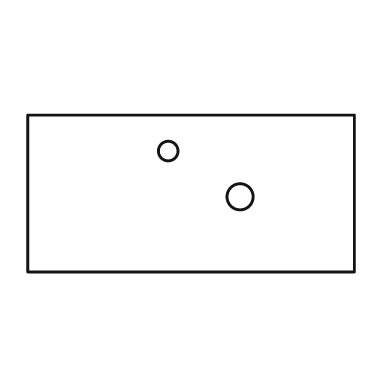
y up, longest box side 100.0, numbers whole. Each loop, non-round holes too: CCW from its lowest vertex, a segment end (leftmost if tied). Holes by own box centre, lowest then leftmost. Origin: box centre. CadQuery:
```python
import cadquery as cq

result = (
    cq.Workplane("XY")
    .moveTo(-50.0, -24.0)
    .lineTo(50.0, -24.0)
    .lineTo(50.0, 24.0)
    .lineTo(-50.0, 24.0)
    .close()
    .moveTo(15.0, -1.0)
    .circle(4.0)
    .moveTo(-7.0, 13.0)
    .circle(3.0)
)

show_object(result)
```